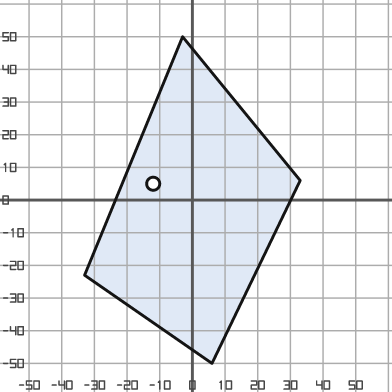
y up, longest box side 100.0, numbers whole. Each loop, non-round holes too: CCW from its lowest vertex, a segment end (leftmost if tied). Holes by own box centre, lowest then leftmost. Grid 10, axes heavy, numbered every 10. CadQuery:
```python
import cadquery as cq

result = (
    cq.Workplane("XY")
    .moveTo(6.0, -50.0)
    .lineTo(33.0, 6.0)
    .lineTo(-3.0, 50.0)
    .lineTo(-33.0, -23.0)
    .close()
    .moveTo(-12.0, 5.0)
    .circle(2.0)
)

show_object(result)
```